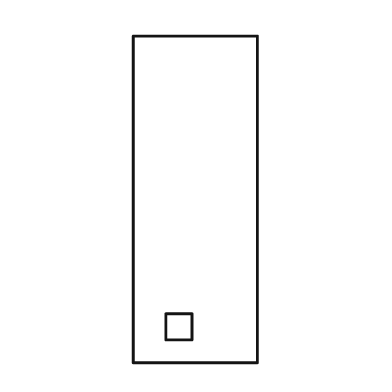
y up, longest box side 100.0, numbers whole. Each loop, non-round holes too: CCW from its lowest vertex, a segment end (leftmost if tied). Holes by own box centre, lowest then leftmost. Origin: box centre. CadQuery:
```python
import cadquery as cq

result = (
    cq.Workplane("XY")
    .moveTo(-19.0, -50.0)
    .lineTo(19.0, -50.0)
    .lineTo(19.0, 50.0)
    .lineTo(-19.0, 50.0)
    .close()
    .moveTo(-9.0, -43.0)
    .lineTo(-1.0, -43.0)
    .lineTo(-1.0, -35.0)
    .lineTo(-9.0, -35.0)
    .close()
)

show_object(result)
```